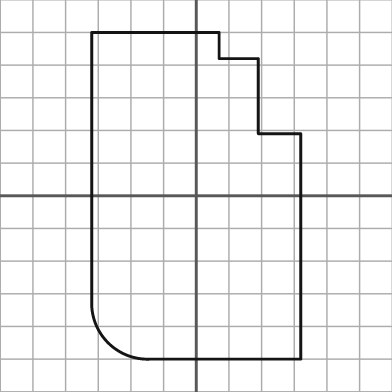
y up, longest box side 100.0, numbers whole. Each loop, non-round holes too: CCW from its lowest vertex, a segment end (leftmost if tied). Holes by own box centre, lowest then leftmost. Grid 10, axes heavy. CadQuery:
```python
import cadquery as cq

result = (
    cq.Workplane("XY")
    .moveTo(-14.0, -50.0)
    .lineTo(32.0, -50.0)
    .lineTo(32.0, 19.0)
    .lineTo(19.0, 19.0)
    .lineTo(19.0, 42.0)
    .lineTo(7.0, 42.0)
    .lineTo(7.0, 50.0)
    .lineTo(-32.0, 50.0)
    .lineTo(-32.0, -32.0)
    .threePointArc((-27.0, -45.0), (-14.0, -50.0))
    .close()
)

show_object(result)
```